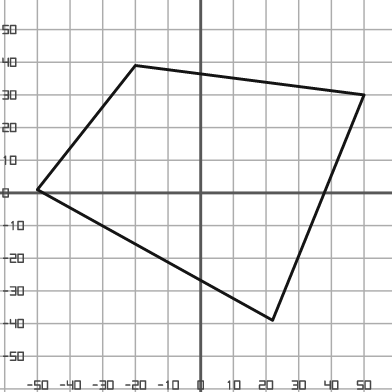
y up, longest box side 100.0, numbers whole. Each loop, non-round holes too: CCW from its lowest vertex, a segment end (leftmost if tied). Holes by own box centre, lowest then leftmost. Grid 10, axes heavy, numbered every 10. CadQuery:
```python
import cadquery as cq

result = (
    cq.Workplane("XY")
    .moveTo(22.0, -39.0)
    .lineTo(50.0, 30.0)
    .lineTo(-20.0, 39.0)
    .lineTo(-50.0, 1.0)
    .close()
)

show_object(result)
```